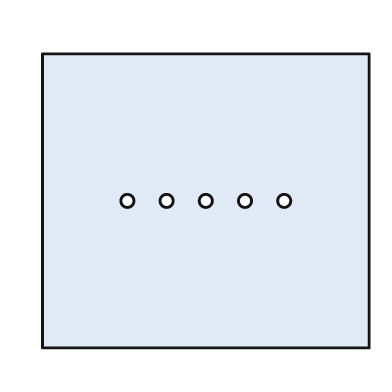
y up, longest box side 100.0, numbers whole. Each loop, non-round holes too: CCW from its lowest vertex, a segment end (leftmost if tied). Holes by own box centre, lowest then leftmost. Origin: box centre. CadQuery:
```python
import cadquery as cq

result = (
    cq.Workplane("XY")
    .moveTo(-50.0, -45.0)
    .lineTo(50.0, -45.0)
    .lineTo(50.0, 45.0)
    .lineTo(-50.0, 45.0)
    .close()
    .moveTo(-24.0, 0.0)
    .circle(2.0)
    .moveTo(-12.0, 0.0)
    .circle(2.0)
    .moveTo(0.0, 0.0)
    .circle(2.0)
    .moveTo(12.0, 0.0)
    .circle(2.0)
    .moveTo(24.0, 0.0)
    .circle(2.0)
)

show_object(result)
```